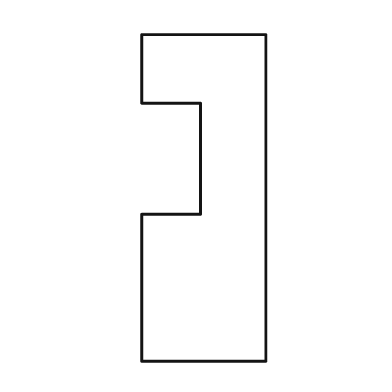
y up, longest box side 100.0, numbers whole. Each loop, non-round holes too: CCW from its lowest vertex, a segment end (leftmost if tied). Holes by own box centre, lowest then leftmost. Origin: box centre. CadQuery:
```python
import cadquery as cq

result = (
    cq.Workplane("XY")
    .moveTo(-19.0, -50.0)
    .lineTo(19.0, -50.0)
    .lineTo(19.0, 50.0)
    .lineTo(-19.0, 50.0)
    .lineTo(-19.0, 29.0)
    .lineTo(-1.0, 29.0)
    .lineTo(-1.0, -5.0)
    .lineTo(-19.0, -5.0)
    .close()
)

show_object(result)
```